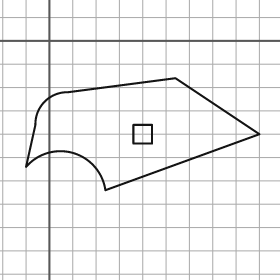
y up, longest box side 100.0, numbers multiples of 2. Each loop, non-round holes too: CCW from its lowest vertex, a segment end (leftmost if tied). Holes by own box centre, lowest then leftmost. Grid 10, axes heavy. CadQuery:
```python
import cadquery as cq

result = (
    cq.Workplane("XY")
    .moveTo(24.0, -64.0)
    .lineTo(90.0, -40.0)
    .lineTo(54.0, -16.0)
    .lineTo(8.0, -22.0)
    .threePointArc((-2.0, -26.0), (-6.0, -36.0))
    .lineTo(-10.0, -54.0)
    .threePointArc((10.0, -48.0), (24.0, -64.0))
    .close()
    .moveTo(36.0, -44.0)
    .lineTo(44.0, -44.0)
    .lineTo(44.0, -36.0)
    .lineTo(36.0, -36.0)
    .close()
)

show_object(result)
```